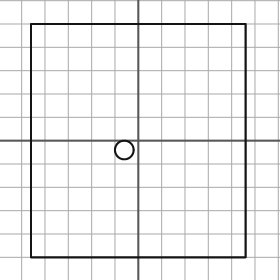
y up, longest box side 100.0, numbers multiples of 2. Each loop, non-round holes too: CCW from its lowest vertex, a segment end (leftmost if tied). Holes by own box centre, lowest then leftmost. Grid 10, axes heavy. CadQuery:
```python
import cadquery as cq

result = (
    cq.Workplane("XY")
    .moveTo(-46.0, -50.0)
    .lineTo(46.0, -50.0)
    .lineTo(46.0, 50.0)
    .lineTo(-46.0, 50.0)
    .close()
    .moveTo(-6.0, -4.0)
    .circle(4.0)
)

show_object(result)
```